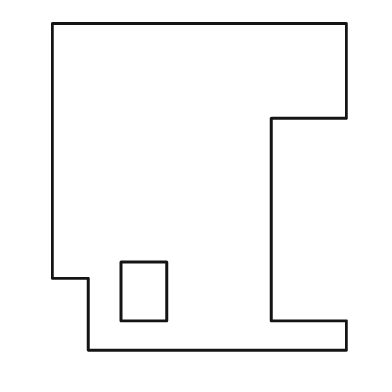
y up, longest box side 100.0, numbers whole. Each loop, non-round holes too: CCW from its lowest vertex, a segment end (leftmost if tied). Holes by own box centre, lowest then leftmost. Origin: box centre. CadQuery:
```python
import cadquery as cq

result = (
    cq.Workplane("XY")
    .moveTo(-34.0, -50.0)
    .lineTo(45.0, -50.0)
    .lineTo(45.0, -41.0)
    .lineTo(22.0, -41.0)
    .lineTo(22.0, 21.0)
    .lineTo(45.0, 21.0)
    .lineTo(45.0, 50.0)
    .lineTo(-45.0, 50.0)
    .lineTo(-45.0, -28.0)
    .lineTo(-34.0, -28.0)
    .close()
    .moveTo(-24.0, -41.0)
    .lineTo(-10.0, -41.0)
    .lineTo(-10.0, -23.0)
    .lineTo(-24.0, -23.0)
    .close()
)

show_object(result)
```